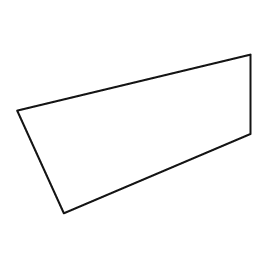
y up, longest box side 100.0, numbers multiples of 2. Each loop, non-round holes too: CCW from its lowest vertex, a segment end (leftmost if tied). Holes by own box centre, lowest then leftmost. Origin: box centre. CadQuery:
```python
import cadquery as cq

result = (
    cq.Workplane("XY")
    .moveTo(-30.0, -34.0)
    .lineTo(50.0, 0.0)
    .lineTo(50.0, 34.0)
    .lineTo(-50.0, 10.0)
    .close()
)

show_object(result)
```